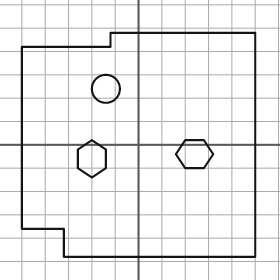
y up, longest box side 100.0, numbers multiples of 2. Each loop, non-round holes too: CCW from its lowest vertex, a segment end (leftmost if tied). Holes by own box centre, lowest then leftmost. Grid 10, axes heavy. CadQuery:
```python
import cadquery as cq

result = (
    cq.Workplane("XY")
    .moveTo(-32.0, -48.0)
    .lineTo(50.0, -48.0)
    .lineTo(50.0, 48.0)
    .lineTo(-12.0, 48.0)
    .lineTo(-12.0, 42.0)
    .lineTo(-50.0, 42.0)
    .lineTo(-50.0, -36.0)
    .lineTo(-32.0, -36.0)
    .close()
    .moveTo(-20.0, -14.0)
    .lineTo(-14.0, -10.0)
    .lineTo(-14.0, -2.0)
    .lineTo(-20.0, 2.0)
    .lineTo(-26.0, -2.0)
    .lineTo(-26.0, -10.0)
    .close()
    .moveTo(20.0, -10.0)
    .lineTo(28.0, -10.0)
    .lineTo(32.0, -4.0)
    .lineTo(28.0, 2.0)
    .lineTo(20.0, 2.0)
    .lineTo(16.0, -4.0)
    .close()
    .moveTo(-14.0, 24.0)
    .circle(6.0)
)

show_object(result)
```